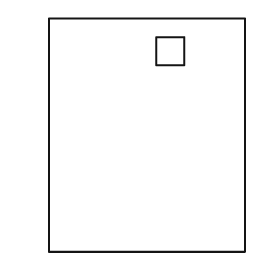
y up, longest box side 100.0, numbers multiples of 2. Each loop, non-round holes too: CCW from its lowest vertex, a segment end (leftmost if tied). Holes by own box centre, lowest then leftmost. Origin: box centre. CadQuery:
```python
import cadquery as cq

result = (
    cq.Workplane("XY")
    .moveTo(-42.0, -50.0)
    .lineTo(42.0, -50.0)
    .lineTo(42.0, 50.0)
    .lineTo(-42.0, 50.0)
    .close()
    .moveTo(4.0, 30.0)
    .lineTo(16.0, 30.0)
    .lineTo(16.0, 42.0)
    .lineTo(4.0, 42.0)
    .close()
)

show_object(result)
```